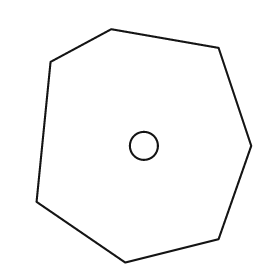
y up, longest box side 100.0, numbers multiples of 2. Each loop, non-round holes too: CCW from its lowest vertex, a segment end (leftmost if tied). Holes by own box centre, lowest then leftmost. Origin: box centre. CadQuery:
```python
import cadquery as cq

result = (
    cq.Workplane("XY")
    .moveTo(-8.0, -50.0)
    .lineTo(32.0, -40.0)
    .lineTo(46.0, 0.0)
    .lineTo(32.0, 42.0)
    .lineTo(-14.0, 50.0)
    .lineTo(-40.0, 36.0)
    .lineTo(-46.0, -24.0)
    .close()
    .moveTo(0.0, 0.0)
    .circle(6.0)
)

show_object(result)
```